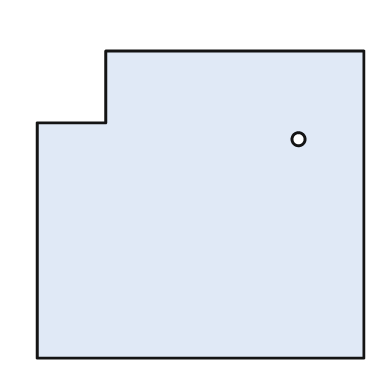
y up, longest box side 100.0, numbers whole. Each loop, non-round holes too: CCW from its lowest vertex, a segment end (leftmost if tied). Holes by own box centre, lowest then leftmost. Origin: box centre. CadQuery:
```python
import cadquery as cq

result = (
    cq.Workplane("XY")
    .moveTo(-50.0, -47.0)
    .lineTo(50.0, -47.0)
    .lineTo(50.0, 47.0)
    .lineTo(-29.0, 47.0)
    .lineTo(-29.0, 25.0)
    .lineTo(-50.0, 25.0)
    .close()
    .moveTo(30.0, 20.0)
    .circle(2.0)
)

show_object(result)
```